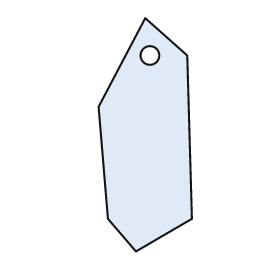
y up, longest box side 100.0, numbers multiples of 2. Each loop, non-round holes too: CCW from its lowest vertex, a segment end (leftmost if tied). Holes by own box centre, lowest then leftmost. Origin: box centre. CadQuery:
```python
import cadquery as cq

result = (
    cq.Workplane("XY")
    .moveTo(-4.0, -50.0)
    .lineTo(20.0, -36.0)
    .lineTo(18.0, 34.0)
    .lineTo(0.0, 50.0)
    .lineTo(-20.0, 12.0)
    .lineTo(-16.0, -36.0)
    .close()
    .moveTo(2.0, 34.0)
    .circle(4.0)
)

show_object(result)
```